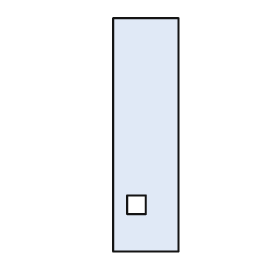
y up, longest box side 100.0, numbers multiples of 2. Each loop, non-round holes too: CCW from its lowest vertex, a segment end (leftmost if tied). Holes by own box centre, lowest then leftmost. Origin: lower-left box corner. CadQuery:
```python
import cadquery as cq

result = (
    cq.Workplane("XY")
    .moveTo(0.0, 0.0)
    .lineTo(28.0, 0.0)
    .lineTo(28.0, 100.0)
    .lineTo(0.0, 100.0)
    .close()
    .moveTo(6.0, 16.0)
    .lineTo(14.0, 16.0)
    .lineTo(14.0, 24.0)
    .lineTo(6.0, 24.0)
    .close()
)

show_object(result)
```